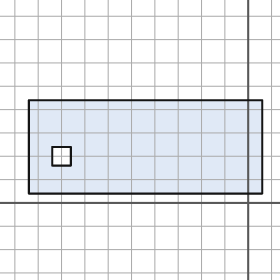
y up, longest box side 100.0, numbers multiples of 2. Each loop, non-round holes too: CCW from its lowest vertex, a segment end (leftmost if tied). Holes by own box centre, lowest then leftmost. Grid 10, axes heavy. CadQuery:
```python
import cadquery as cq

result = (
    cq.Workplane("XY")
    .moveTo(-94.0, 4.0)
    .lineTo(6.0, 4.0)
    .lineTo(6.0, 44.0)
    .lineTo(-94.0, 44.0)
    .close()
    .moveTo(-84.0, 16.0)
    .lineTo(-76.0, 16.0)
    .lineTo(-76.0, 24.0)
    .lineTo(-84.0, 24.0)
    .close()
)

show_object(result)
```